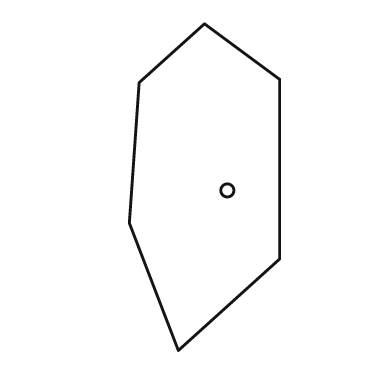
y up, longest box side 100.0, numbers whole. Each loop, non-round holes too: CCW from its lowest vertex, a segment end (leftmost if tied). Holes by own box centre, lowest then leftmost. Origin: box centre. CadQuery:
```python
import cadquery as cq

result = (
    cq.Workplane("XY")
    .moveTo(-8.0, -50.0)
    .lineTo(23.0, -22.0)
    .lineTo(23.0, 33.0)
    .lineTo(0.0, 50.0)
    .lineTo(-20.0, 32.0)
    .lineTo(-23.0, -11.0)
    .close()
    .moveTo(7.0, -1.0)
    .circle(2.0)
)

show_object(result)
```